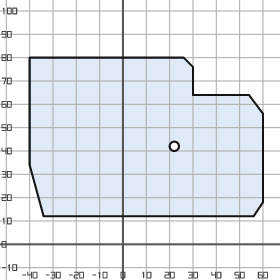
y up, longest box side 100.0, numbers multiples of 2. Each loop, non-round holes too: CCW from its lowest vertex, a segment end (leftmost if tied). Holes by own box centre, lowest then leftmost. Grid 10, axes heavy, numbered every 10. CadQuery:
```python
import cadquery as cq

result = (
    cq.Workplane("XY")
    .moveTo(-34.0, 12.0)
    .lineTo(56.0, 12.0)
    .lineTo(60.0, 18.0)
    .lineTo(60.0, 56.0)
    .lineTo(54.0, 64.0)
    .lineTo(30.0, 64.0)
    .lineTo(30.0, 76.0)
    .lineTo(26.0, 80.0)
    .lineTo(-40.0, 80.0)
    .lineTo(-40.0, 34.0)
    .close()
    .moveTo(22.0, 42.0)
    .circle(2.0)
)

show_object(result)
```